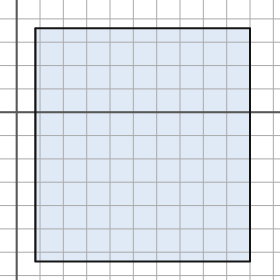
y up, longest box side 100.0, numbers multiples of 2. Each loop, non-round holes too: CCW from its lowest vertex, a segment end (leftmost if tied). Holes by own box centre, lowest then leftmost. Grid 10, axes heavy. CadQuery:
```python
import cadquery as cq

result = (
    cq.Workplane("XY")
    .moveTo(8.0, -64.0)
    .lineTo(100.0, -64.0)
    .lineTo(100.0, 36.0)
    .lineTo(8.0, 36.0)
    .close()
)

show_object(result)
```